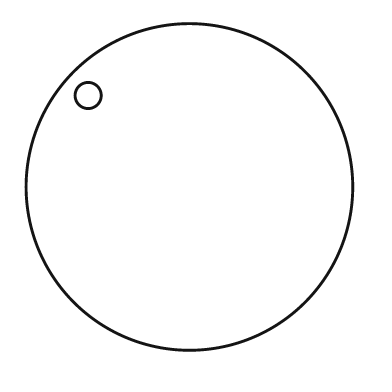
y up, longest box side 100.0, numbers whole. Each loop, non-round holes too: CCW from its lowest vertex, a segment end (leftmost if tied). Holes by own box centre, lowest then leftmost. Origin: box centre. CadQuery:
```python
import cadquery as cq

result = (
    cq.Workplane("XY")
    .moveTo(0.0, 0.0)
    .circle(50.0)
    .moveTo(-31.0, 28.0)
    .circle(4.0)
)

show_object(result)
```